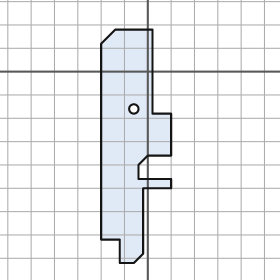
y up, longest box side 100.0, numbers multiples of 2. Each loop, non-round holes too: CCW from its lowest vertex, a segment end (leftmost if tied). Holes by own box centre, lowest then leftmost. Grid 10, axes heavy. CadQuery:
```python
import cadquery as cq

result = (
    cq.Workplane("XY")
    .moveTo(-12.0, -82.0)
    .lineTo(-6.0, -82.0)
    .lineTo(-2.0, -78.0)
    .lineTo(-2.0, -50.0)
    .lineTo(10.0, -50.0)
    .lineTo(10.0, -46.0)
    .lineTo(-4.0, -46.0)
    .lineTo(-4.0, -40.0)
    .lineTo(0.0, -36.0)
    .lineTo(10.0, -36.0)
    .lineTo(10.0, -18.0)
    .lineTo(2.0, -18.0)
    .lineTo(2.0, 18.0)
    .lineTo(-14.0, 18.0)
    .lineTo(-20.0, 12.0)
    .lineTo(-20.0, -72.0)
    .lineTo(-12.0, -72.0)
    .close()
    .moveTo(-6.0, -16.0)
    .circle(2.0)
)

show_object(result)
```